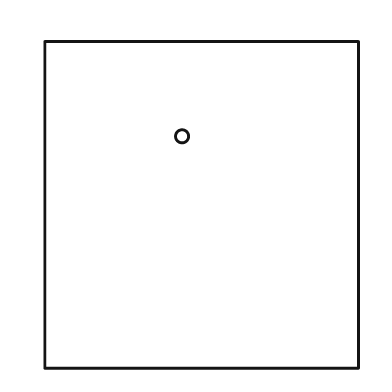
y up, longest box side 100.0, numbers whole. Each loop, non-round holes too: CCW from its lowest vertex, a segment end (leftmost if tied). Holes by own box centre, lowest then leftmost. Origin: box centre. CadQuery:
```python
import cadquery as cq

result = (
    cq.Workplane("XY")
    .moveTo(-48.0, -50.0)
    .lineTo(48.0, -50.0)
    .lineTo(48.0, 50.0)
    .lineTo(-48.0, 50.0)
    .close()
    .moveTo(-6.0, 21.0)
    .circle(2.0)
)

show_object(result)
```